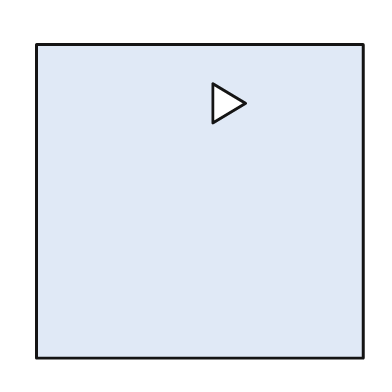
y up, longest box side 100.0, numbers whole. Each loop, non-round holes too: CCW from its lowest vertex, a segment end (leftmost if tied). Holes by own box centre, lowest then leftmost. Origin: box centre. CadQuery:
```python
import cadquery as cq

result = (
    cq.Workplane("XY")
    .moveTo(-50.0, -48.0)
    .lineTo(50.0, -48.0)
    .lineTo(50.0, 48.0)
    .lineTo(-50.0, 48.0)
    .close()
    .moveTo(4.0, 24.0)
    .lineTo(14.0, 30.0)
    .lineTo(4.0, 36.0)
    .close()
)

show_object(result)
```